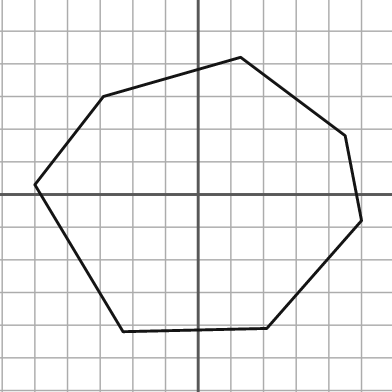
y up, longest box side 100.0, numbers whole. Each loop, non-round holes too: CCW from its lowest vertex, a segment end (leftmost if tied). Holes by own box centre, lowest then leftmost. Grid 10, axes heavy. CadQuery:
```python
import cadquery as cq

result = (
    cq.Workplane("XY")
    .moveTo(-23.0, -42.0)
    .lineTo(21.0, -41.0)
    .lineTo(50.0, -8.0)
    .lineTo(45.0, 18.0)
    .lineTo(13.0, 42.0)
    .lineTo(-29.0, 30.0)
    .lineTo(-50.0, 3.0)
    .close()
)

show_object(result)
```